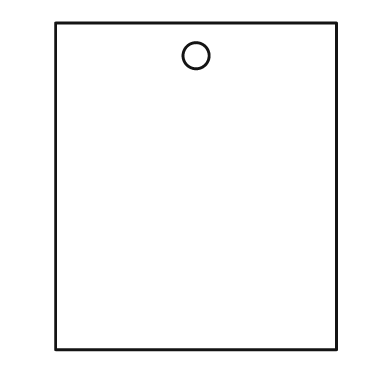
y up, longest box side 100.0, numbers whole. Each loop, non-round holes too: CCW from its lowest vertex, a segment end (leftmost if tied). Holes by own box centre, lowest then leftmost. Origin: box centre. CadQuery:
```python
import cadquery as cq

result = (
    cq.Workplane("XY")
    .moveTo(-43.0, -50.0)
    .lineTo(43.0, -50.0)
    .lineTo(43.0, 50.0)
    .lineTo(-43.0, 50.0)
    .close()
    .moveTo(0.0, 40.0)
    .circle(4.0)
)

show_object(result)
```